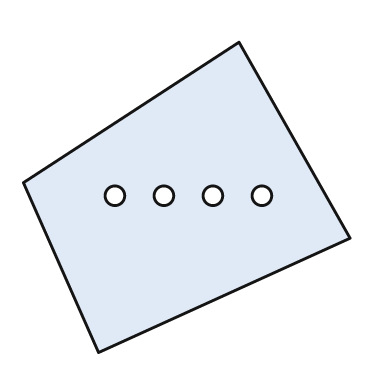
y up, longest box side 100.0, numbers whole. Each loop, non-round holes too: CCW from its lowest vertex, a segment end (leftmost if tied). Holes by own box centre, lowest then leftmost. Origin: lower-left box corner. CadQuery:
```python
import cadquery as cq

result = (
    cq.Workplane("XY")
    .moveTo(23.0, 0.0)
    .lineTo(100.0, 35.0)
    .lineTo(66.0, 95.0)
    .lineTo(0.0, 52.0)
    .close()
    .moveTo(28.0, 48.0)
    .circle(3.0)
    .moveTo(43.0, 48.0)
    .circle(3.0)
    .moveTo(58.0, 48.0)
    .circle(3.0)
    .moveTo(73.0, 48.0)
    .circle(3.0)
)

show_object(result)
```